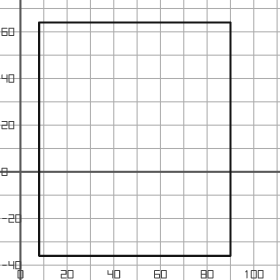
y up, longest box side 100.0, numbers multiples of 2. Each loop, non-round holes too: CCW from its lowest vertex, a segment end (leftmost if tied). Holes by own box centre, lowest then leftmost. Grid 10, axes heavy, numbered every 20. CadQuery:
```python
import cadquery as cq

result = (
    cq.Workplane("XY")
    .moveTo(8.0, -36.0)
    .lineTo(90.0, -36.0)
    .lineTo(90.0, 64.0)
    .lineTo(8.0, 64.0)
    .close()
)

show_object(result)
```